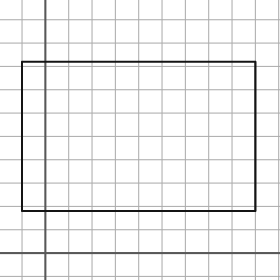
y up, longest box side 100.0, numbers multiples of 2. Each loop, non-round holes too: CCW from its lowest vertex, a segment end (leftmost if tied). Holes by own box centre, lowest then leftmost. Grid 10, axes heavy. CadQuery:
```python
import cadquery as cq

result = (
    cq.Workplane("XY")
    .moveTo(-10.0, 18.0)
    .lineTo(90.0, 18.0)
    .lineTo(90.0, 82.0)
    .lineTo(-10.0, 82.0)
    .close()
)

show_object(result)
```